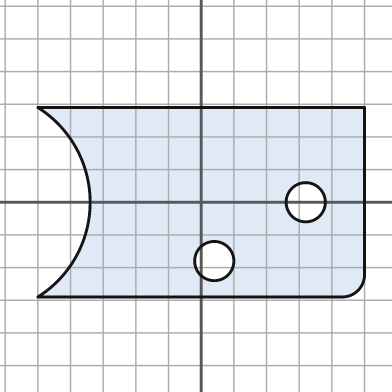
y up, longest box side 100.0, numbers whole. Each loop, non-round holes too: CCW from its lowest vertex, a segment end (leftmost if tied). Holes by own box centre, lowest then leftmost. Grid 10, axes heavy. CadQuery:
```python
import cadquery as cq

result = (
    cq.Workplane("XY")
    .moveTo(-50.0, -29.0)
    .lineTo(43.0, -29.0)
    .threePointArc((48.0, -27.0), (50.0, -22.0))
    .lineTo(50.0, 29.0)
    .lineTo(-50.0, 29.0)
    .threePointArc((-34.0, 0.0), (-50.0, -29.0))
    .close()
    .moveTo(4.0, -18.0)
    .circle(6.0)
    .moveTo(32.0, 0.0)
    .circle(6.0)
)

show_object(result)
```